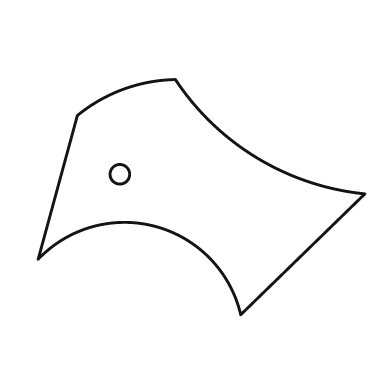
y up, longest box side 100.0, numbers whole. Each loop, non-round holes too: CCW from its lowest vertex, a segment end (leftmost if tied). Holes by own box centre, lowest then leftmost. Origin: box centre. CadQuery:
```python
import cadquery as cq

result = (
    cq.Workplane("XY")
    .moveTo(12.0, -36.0)
    .lineTo(50.0, 1.0)
    .threePointArc((17.0, 12.0), (-8.0, 36.0))
    .threePointArc((-24.0, 33.0), (-38.0, 25.0))
    .lineTo(-50.0, -19.0)
    .threePointArc((-14.0, -9.0), (12.0, -36.0))
    .close()
    .moveTo(-25.0, 7.0)
    .circle(3.0)
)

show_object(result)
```